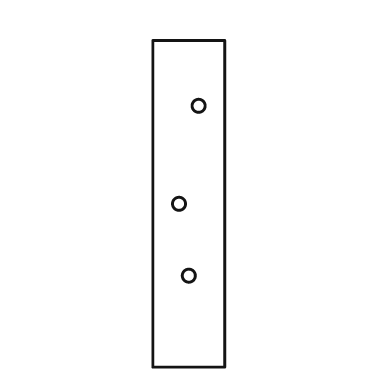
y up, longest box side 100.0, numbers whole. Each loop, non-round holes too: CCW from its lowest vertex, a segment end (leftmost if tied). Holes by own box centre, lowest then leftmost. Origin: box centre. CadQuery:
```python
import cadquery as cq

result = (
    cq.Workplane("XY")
    .moveTo(-11.0, -50.0)
    .lineTo(11.0, -50.0)
    .lineTo(11.0, 50.0)
    .lineTo(-11.0, 50.0)
    .close()
    .moveTo(0.0, -22.0)
    .circle(2.0)
    .moveTo(-3.0, 0.0)
    .circle(2.0)
    .moveTo(3.0, 30.0)
    .circle(2.0)
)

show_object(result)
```